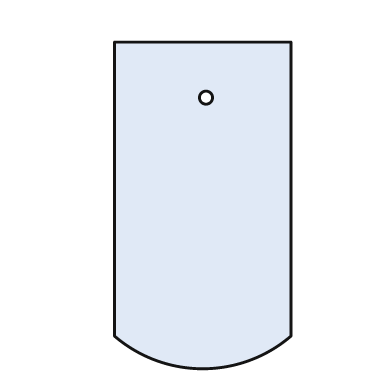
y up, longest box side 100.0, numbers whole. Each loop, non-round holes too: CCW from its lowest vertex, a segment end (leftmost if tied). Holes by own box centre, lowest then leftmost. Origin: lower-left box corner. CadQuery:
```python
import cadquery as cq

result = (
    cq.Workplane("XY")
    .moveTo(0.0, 10.0)
    .threePointArc((27.0, 0.0), (54.0, 10.0))
    .lineTo(54.0, 100.0)
    .lineTo(0.0, 100.0)
    .close()
    .moveTo(28.0, 83.0)
    .circle(2.0)
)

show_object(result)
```